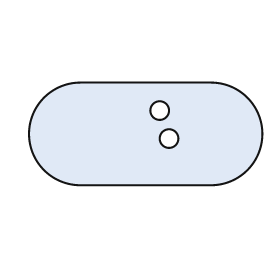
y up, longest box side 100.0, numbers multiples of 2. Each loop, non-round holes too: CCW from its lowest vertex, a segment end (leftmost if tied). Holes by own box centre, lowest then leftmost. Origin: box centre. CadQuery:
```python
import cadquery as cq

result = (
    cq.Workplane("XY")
    .moveTo(-28.0, -22.0)
    .lineTo(28.0, -22.0)
    .threePointArc((50.0, 0.0), (28.0, 22.0))
    .lineTo(-28.0, 22.0)
    .threePointArc((-50.0, 0.0), (-28.0, -22.0))
    .close()
    .moveTo(10.0, -2.0)
    .circle(4.0)
    .moveTo(6.0, 10.0)
    .circle(4.0)
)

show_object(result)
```